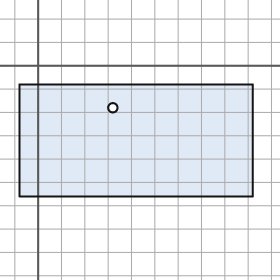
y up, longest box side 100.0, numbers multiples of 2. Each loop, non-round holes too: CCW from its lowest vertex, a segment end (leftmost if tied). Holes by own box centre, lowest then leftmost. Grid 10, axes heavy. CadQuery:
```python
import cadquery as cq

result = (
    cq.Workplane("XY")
    .moveTo(-8.0, -56.0)
    .lineTo(92.0, -56.0)
    .lineTo(92.0, -8.0)
    .lineTo(-8.0, -8.0)
    .close()
    .moveTo(32.0, -18.0)
    .circle(2.0)
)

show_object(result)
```